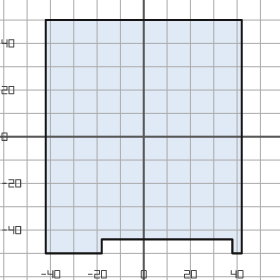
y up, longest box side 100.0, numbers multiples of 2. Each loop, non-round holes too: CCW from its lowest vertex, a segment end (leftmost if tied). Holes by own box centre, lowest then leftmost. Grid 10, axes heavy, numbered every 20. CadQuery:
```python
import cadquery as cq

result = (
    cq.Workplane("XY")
    .moveTo(-42.0, -50.0)
    .lineTo(-18.0, -50.0)
    .lineTo(-18.0, -44.0)
    .lineTo(38.0, -44.0)
    .lineTo(38.0, -50.0)
    .lineTo(42.0, -50.0)
    .lineTo(42.0, 50.0)
    .lineTo(-42.0, 50.0)
    .close()
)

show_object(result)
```